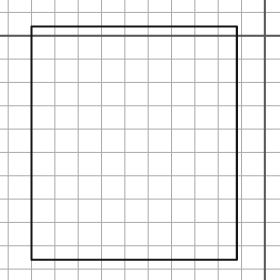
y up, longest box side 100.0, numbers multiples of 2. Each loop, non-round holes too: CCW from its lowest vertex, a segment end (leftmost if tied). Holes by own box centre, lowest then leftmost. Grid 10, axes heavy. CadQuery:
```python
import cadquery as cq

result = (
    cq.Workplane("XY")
    .moveTo(-100.0, -96.0)
    .lineTo(-12.0, -96.0)
    .lineTo(-12.0, 4.0)
    .lineTo(-100.0, 4.0)
    .close()
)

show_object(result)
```